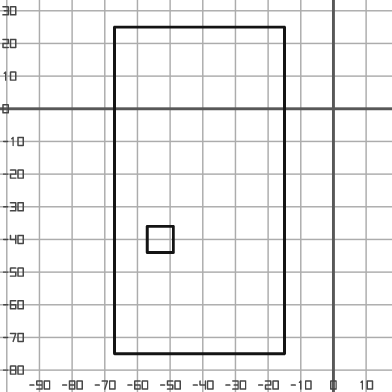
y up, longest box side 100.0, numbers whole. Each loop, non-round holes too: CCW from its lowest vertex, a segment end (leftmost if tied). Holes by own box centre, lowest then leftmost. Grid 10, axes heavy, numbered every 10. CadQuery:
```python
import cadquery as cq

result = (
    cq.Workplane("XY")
    .moveTo(-67.0, -75.0)
    .lineTo(-15.0, -75.0)
    .lineTo(-15.0, 25.0)
    .lineTo(-67.0, 25.0)
    .close()
    .moveTo(-57.0, -44.0)
    .lineTo(-49.0, -44.0)
    .lineTo(-49.0, -36.0)
    .lineTo(-57.0, -36.0)
    .close()
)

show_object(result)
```